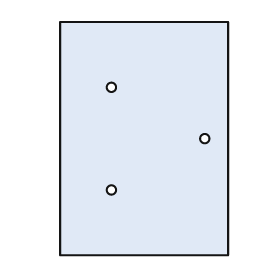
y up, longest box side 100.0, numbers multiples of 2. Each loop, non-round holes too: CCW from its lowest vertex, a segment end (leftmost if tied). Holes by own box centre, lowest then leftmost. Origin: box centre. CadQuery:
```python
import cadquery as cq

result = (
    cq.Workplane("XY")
    .moveTo(-36.0, -50.0)
    .lineTo(36.0, -50.0)
    .lineTo(36.0, 50.0)
    .lineTo(-36.0, 50.0)
    .close()
    .moveTo(-14.0, -22.0)
    .circle(2.0)
    .moveTo(26.0, 0.0)
    .circle(2.0)
    .moveTo(-14.0, 22.0)
    .circle(2.0)
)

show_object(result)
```